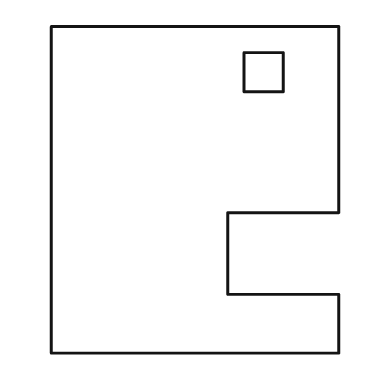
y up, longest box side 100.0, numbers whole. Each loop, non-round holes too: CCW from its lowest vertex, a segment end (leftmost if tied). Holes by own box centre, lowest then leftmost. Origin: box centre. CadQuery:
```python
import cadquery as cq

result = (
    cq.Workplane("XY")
    .moveTo(-44.0, -50.0)
    .lineTo(44.0, -50.0)
    .lineTo(44.0, -32.0)
    .lineTo(10.0, -32.0)
    .lineTo(10.0, -7.0)
    .lineTo(44.0, -7.0)
    .lineTo(44.0, 50.0)
    .lineTo(-44.0, 50.0)
    .close()
    .moveTo(15.0, 30.0)
    .lineTo(27.0, 30.0)
    .lineTo(27.0, 42.0)
    .lineTo(15.0, 42.0)
    .close()
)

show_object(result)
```